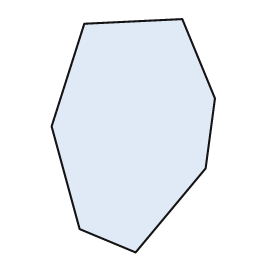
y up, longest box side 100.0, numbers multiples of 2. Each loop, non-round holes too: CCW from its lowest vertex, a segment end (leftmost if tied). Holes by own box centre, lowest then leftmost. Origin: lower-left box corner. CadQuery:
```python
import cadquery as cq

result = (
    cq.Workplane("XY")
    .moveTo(36.0, 0.0)
    .lineTo(66.0, 36.0)
    .lineTo(70.0, 66.0)
    .lineTo(56.0, 100.0)
    .lineTo(14.0, 98.0)
    .lineTo(0.0, 54.0)
    .lineTo(12.0, 10.0)
    .close()
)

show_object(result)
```